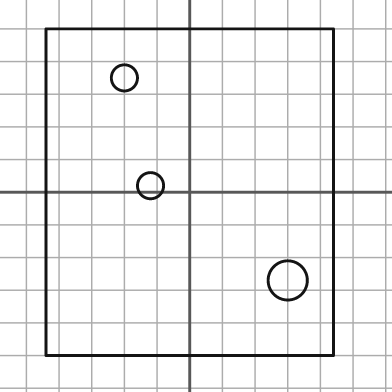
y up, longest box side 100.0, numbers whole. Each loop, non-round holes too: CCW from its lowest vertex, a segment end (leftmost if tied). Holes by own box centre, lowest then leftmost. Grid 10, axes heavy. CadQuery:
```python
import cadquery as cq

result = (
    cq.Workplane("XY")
    .moveTo(-44.0, -50.0)
    .lineTo(44.0, -50.0)
    .lineTo(44.0, 50.0)
    .lineTo(-44.0, 50.0)
    .close()
    .moveTo(30.0, -27.0)
    .circle(6.0)
    .moveTo(-12.0, 2.0)
    .circle(4.0)
    .moveTo(-20.0, 35.0)
    .circle(4.0)
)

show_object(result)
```